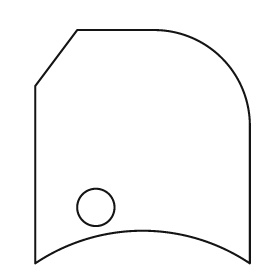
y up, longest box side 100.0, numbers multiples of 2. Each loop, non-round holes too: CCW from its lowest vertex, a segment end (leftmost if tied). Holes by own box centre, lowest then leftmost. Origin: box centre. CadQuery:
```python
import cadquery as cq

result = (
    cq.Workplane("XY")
    .moveTo(-46.0, -50.0)
    .threePointArc((0.0, -36.0), (46.0, -50.0))
    .lineTo(46.0, 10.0)
    .threePointArc((34.0, 38.0), (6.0, 50.0))
    .lineTo(-28.0, 50.0)
    .lineTo(-46.0, 26.0)
    .close()
    .moveTo(-20.0, -26.0)
    .circle(8.0)
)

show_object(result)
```